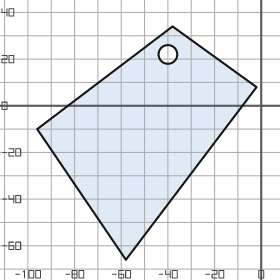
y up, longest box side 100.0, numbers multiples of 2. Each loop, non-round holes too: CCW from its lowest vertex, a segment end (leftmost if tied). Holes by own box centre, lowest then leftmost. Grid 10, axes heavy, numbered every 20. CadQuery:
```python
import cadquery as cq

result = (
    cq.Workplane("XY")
    .moveTo(-58.0, -66.0)
    .lineTo(-2.0, 8.0)
    .lineTo(-38.0, 34.0)
    .lineTo(-96.0, -10.0)
    .close()
    .moveTo(-40.0, 22.0)
    .circle(4.0)
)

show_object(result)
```